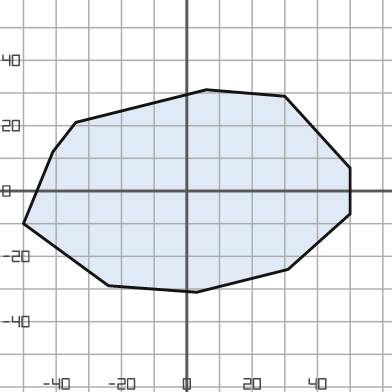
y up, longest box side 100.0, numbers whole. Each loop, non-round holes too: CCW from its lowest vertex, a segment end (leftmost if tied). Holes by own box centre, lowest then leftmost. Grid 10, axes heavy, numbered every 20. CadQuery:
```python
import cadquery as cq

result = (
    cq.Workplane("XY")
    .moveTo(3.0, -31.0)
    .lineTo(31.0, -24.0)
    .lineTo(50.0, -7.0)
    .lineTo(50.0, 7.0)
    .lineTo(30.0, 29.0)
    .lineTo(6.0, 31.0)
    .lineTo(-34.0, 21.0)
    .lineTo(-41.0, 12.0)
    .lineTo(-50.0, -10.0)
    .lineTo(-24.0, -29.0)
    .close()
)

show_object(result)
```